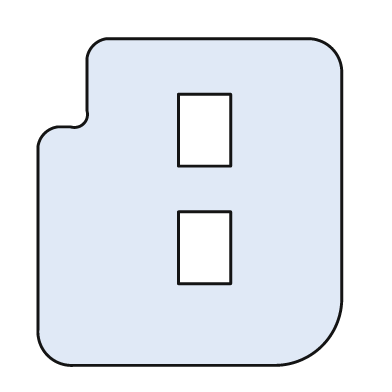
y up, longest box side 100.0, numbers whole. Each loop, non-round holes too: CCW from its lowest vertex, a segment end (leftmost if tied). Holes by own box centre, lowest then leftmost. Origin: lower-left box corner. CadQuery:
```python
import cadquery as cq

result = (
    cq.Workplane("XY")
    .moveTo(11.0, 0.0)
    .lineTo(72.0, 0.0)
    .threePointArc((87.0, 6.0), (93.0, 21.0))
    .lineTo(93.0, 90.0)
    .threePointArc((90.0, 97.0), (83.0, 100.0))
    .lineTo(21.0, 100.0)
    .threePointArc((17.0, 98.0), (15.0, 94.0))
    .lineTo(15.0, 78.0)
    .threePointArc((14.0, 74.0), (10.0, 73.0))
    .lineTo(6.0, 73.0)
    .threePointArc((2.0, 71.0), (0.0, 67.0))
    .lineTo(0.0, 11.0)
    .threePointArc((3.0, 3.0), (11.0, 0.0))
    .close()
    .moveTo(43.0, 25.0)
    .lineTo(59.0, 25.0)
    .lineTo(59.0, 47.0)
    .lineTo(43.0, 47.0)
    .close()
    .moveTo(43.0, 61.0)
    .lineTo(59.0, 61.0)
    .lineTo(59.0, 83.0)
    .lineTo(43.0, 83.0)
    .close()
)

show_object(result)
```